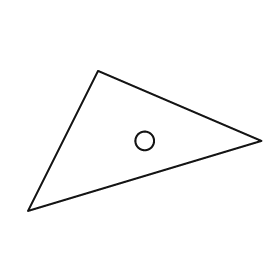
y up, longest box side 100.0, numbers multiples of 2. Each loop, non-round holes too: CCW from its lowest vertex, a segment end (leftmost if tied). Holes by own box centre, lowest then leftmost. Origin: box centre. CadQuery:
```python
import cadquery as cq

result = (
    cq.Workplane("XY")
    .moveTo(-50.0, -30.0)
    .lineTo(50.0, 0.0)
    .lineTo(-20.0, 30.0)
    .close()
    .moveTo(0.0, 0.0)
    .circle(4.0)
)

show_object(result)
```